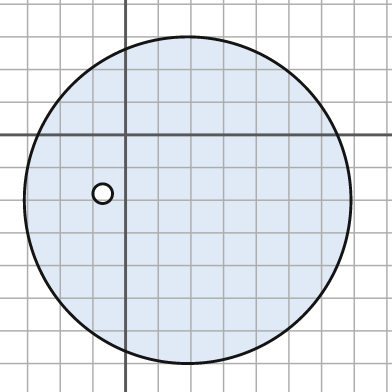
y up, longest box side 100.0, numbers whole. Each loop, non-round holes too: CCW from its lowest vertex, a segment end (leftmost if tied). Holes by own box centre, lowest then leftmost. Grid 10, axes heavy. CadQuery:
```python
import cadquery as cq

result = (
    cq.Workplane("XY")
    .moveTo(19.0, -20.0)
    .circle(50.0)
    .moveTo(-7.0, -18.0)
    .circle(3.0)
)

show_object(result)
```